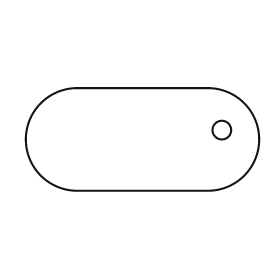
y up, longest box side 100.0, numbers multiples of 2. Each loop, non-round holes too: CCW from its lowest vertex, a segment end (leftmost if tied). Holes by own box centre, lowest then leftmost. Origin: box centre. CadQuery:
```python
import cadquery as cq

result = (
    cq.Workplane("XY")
    .moveTo(-28.0, -22.0)
    .lineTo(28.0, -22.0)
    .threePointArc((50.0, 0.0), (28.0, 22.0))
    .lineTo(-28.0, 22.0)
    .threePointArc((-50.0, 0.0), (-28.0, -22.0))
    .close()
    .moveTo(34.0, 4.0)
    .circle(4.0)
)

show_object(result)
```